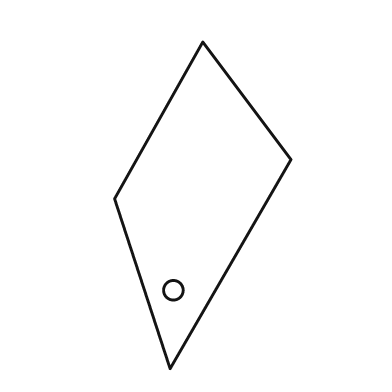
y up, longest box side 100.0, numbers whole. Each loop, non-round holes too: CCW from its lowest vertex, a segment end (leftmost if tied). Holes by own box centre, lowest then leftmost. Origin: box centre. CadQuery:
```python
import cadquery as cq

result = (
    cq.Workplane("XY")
    .moveTo(-10.0, -50.0)
    .lineTo(27.0, 14.0)
    .lineTo(0.0, 50.0)
    .lineTo(-27.0, 2.0)
    .close()
    .moveTo(-9.0, -26.0)
    .circle(3.0)
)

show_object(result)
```